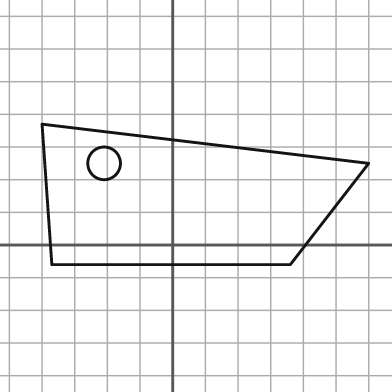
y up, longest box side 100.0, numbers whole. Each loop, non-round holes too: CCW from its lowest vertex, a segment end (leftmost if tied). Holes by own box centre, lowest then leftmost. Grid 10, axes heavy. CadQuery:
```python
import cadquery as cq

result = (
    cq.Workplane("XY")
    .moveTo(-37.0, -6.0)
    .lineTo(36.0, -6.0)
    .lineTo(60.0, 25.0)
    .lineTo(-40.0, 37.0)
    .close()
    .moveTo(-21.0, 25.0)
    .circle(5.0)
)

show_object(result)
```